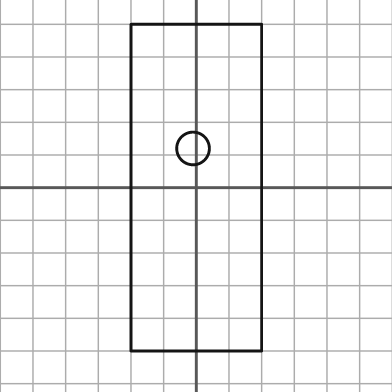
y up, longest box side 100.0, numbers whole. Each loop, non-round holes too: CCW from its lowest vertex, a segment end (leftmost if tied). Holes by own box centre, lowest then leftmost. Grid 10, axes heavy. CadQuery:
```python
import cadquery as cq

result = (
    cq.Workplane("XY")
    .moveTo(-20.0, -50.0)
    .lineTo(20.0, -50.0)
    .lineTo(20.0, 50.0)
    .lineTo(-20.0, 50.0)
    .close()
    .moveTo(-1.0, 12.0)
    .circle(5.0)
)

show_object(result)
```